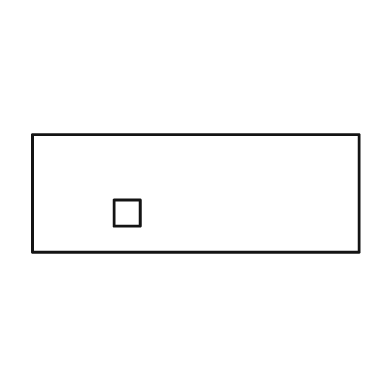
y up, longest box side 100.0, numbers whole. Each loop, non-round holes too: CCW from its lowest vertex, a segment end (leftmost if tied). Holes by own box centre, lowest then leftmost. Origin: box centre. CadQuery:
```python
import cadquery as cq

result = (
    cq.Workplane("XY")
    .moveTo(-50.0, -18.0)
    .lineTo(50.0, -18.0)
    .lineTo(50.0, 18.0)
    .lineTo(-50.0, 18.0)
    .close()
    .moveTo(-25.0, -10.0)
    .lineTo(-17.0, -10.0)
    .lineTo(-17.0, -2.0)
    .lineTo(-25.0, -2.0)
    .close()
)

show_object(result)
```